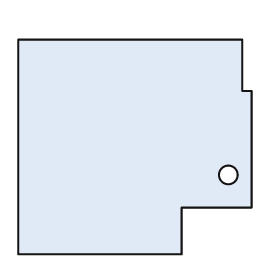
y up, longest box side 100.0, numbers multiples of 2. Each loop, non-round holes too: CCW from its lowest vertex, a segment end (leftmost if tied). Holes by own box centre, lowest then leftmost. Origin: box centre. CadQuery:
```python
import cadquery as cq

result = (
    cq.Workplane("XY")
    .moveTo(-50.0, -46.0)
    .lineTo(20.0, -46.0)
    .lineTo(20.0, -26.0)
    .lineTo(50.0, -26.0)
    .lineTo(50.0, 24.0)
    .lineTo(46.0, 24.0)
    .lineTo(46.0, 46.0)
    .lineTo(-50.0, 46.0)
    .close()
    .moveTo(40.0, -12.0)
    .circle(4.0)
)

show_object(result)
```